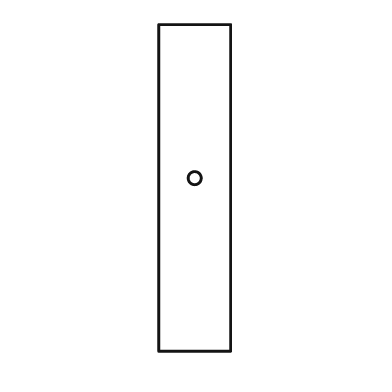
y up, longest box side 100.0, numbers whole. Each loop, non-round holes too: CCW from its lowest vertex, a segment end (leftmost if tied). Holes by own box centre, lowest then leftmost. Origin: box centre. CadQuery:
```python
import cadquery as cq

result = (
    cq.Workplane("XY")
    .moveTo(-11.0, -50.0)
    .lineTo(11.0, -50.0)
    .lineTo(11.0, 50.0)
    .lineTo(-11.0, 50.0)
    .close()
    .moveTo(0.0, 3.0)
    .circle(2.0)
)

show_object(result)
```